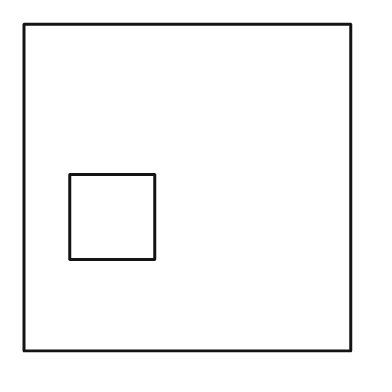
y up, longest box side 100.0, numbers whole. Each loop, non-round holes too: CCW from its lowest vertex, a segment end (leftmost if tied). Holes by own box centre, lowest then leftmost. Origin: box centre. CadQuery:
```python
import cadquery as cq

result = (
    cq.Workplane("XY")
    .moveTo(-50.0, -50.0)
    .lineTo(50.0, -50.0)
    .lineTo(50.0, 50.0)
    .lineTo(-50.0, 50.0)
    .close()
    .moveTo(-36.0, -22.0)
    .lineTo(-10.0, -22.0)
    .lineTo(-10.0, 4.0)
    .lineTo(-36.0, 4.0)
    .close()
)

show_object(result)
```